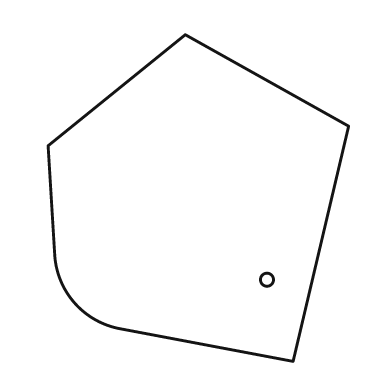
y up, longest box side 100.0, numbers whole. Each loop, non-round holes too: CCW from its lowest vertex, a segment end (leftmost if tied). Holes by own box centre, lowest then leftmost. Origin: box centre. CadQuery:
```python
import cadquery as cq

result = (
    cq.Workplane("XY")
    .moveTo(29.0, -50.0)
    .lineTo(46.0, 22.0)
    .lineTo(-4.0, 50.0)
    .lineTo(-46.0, 16.0)
    .lineTo(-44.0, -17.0)
    .threePointArc((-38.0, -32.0), (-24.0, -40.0))
    .close()
    .moveTo(21.0, -25.0)
    .circle(2.0)
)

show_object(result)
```